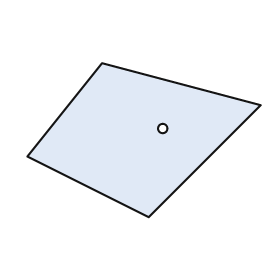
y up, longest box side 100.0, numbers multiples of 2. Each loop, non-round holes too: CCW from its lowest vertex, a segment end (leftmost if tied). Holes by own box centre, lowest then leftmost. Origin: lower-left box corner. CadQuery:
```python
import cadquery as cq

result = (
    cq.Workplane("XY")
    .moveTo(52.0, 0.0)
    .lineTo(100.0, 48.0)
    .lineTo(32.0, 66.0)
    .lineTo(0.0, 26.0)
    .close()
    .moveTo(58.0, 38.0)
    .circle(2.0)
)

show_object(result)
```